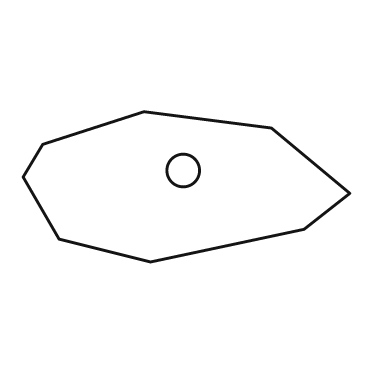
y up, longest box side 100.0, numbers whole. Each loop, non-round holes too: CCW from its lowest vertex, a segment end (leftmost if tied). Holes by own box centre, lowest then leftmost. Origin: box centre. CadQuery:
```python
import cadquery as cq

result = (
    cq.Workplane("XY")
    .moveTo(-11.0, -23.0)
    .lineTo(36.0, -13.0)
    .lineTo(50.0, -2.0)
    .lineTo(26.0, 18.0)
    .lineTo(-13.0, 23.0)
    .lineTo(-44.0, 13.0)
    .lineTo(-50.0, 3.0)
    .lineTo(-39.0, -16.0)
    .close()
    .moveTo(-1.0, 5.0)
    .circle(5.0)
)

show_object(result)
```